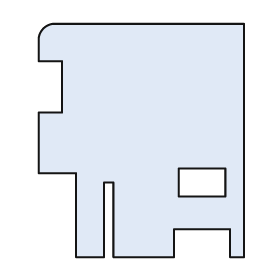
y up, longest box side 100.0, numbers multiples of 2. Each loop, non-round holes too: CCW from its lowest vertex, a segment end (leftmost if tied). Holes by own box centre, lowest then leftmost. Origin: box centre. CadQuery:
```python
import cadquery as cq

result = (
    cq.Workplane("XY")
    .moveTo(-28.0, -50.0)
    .lineTo(-16.0, -50.0)
    .lineTo(-16.0, -18.0)
    .lineTo(-12.0, -18.0)
    .lineTo(-12.0, -50.0)
    .lineTo(14.0, -50.0)
    .lineTo(14.0, -38.0)
    .lineTo(38.0, -38.0)
    .lineTo(38.0, -50.0)
    .lineTo(44.0, -50.0)
    .lineTo(44.0, 50.0)
    .lineTo(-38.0, 50.0)
    .threePointArc((-42.0, 48.0), (-44.0, 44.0))
    .lineTo(-44.0, 34.0)
    .lineTo(-34.0, 34.0)
    .lineTo(-34.0, 12.0)
    .lineTo(-44.0, 12.0)
    .lineTo(-44.0, -14.0)
    .lineTo(-28.0, -14.0)
    .close()
    .moveTo(16.0, -24.0)
    .lineTo(36.0, -24.0)
    .lineTo(36.0, -12.0)
    .lineTo(16.0, -12.0)
    .close()
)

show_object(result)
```